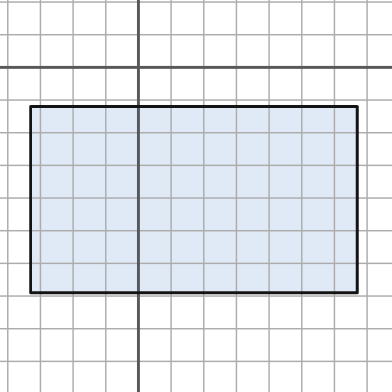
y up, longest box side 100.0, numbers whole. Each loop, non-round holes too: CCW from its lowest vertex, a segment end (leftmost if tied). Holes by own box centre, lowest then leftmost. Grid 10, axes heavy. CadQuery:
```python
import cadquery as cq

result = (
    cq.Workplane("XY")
    .moveTo(-33.0, -69.0)
    .lineTo(67.0, -69.0)
    .lineTo(67.0, -12.0)
    .lineTo(-33.0, -12.0)
    .close()
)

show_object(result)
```